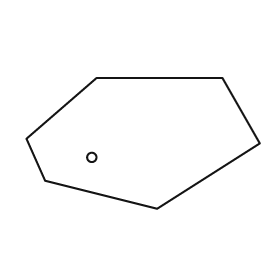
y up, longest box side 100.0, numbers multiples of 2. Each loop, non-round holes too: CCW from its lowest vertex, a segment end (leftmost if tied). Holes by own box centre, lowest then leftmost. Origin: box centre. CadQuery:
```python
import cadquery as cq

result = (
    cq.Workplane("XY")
    .moveTo(6.0, -28.0)
    .lineTo(50.0, 0.0)
    .lineTo(34.0, 28.0)
    .lineTo(-20.0, 28.0)
    .lineTo(-50.0, 2.0)
    .lineTo(-42.0, -16.0)
    .close()
    .moveTo(-22.0, -6.0)
    .circle(2.0)
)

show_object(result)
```